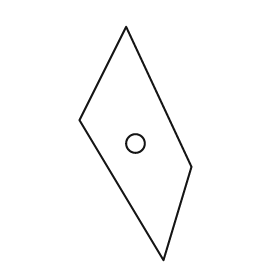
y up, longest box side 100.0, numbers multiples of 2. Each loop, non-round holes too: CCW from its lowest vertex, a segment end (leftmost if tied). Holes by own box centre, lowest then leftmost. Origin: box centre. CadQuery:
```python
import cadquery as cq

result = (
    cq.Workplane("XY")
    .moveTo(12.0, -50.0)
    .lineTo(24.0, -10.0)
    .lineTo(-4.0, 50.0)
    .lineTo(-24.0, 10.0)
    .close()
    .moveTo(0.0, 0.0)
    .circle(4.0)
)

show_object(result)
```